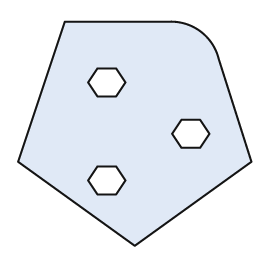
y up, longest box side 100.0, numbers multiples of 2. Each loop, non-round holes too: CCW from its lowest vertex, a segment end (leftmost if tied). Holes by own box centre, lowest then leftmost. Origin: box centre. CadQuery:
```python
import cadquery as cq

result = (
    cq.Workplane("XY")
    .moveTo(0.0, -48.0)
    .lineTo(50.0, -12.0)
    .lineTo(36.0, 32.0)
    .threePointArc((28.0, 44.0), (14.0, 48.0))
    .lineTo(-30.0, 48.0)
    .lineTo(-50.0, -12.0)
    .close()
    .moveTo(-16.0, -26.0)
    .lineTo(-8.0, -26.0)
    .lineTo(-4.0, -20.0)
    .lineTo(-8.0, -14.0)
    .lineTo(-16.0, -14.0)
    .lineTo(-20.0, -20.0)
    .close()
    .moveTo(20.0, -6.0)
    .lineTo(28.0, -6.0)
    .lineTo(32.0, 0.0)
    .lineTo(28.0, 6.0)
    .lineTo(20.0, 6.0)
    .lineTo(16.0, 0.0)
    .close()
    .moveTo(-16.0, 16.0)
    .lineTo(-8.0, 16.0)
    .lineTo(-4.0, 22.0)
    .lineTo(-8.0, 28.0)
    .lineTo(-16.0, 28.0)
    .lineTo(-20.0, 22.0)
    .close()
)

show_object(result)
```